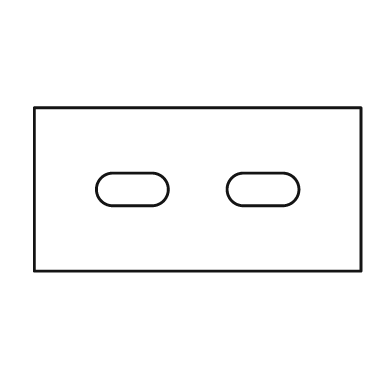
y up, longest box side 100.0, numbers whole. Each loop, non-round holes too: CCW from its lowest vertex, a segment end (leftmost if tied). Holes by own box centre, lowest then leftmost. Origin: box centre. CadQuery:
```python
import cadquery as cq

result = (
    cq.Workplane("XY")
    .moveTo(-50.0, -25.0)
    .lineTo(50.0, -25.0)
    .lineTo(50.0, 25.0)
    .lineTo(-50.0, 25.0)
    .close()
    .moveTo(-26.0, -5.0)
    .lineTo(-14.0, -5.0)
    .threePointArc((-9.0, 0.0), (-14.0, 5.0))
    .lineTo(-26.0, 5.0)
    .threePointArc((-31.0, 0.0), (-26.0, -5.0))
    .close()
    .moveTo(14.0, -5.0)
    .lineTo(26.0, -5.0)
    .threePointArc((31.0, 0.0), (26.0, 5.0))
    .lineTo(14.0, 5.0)
    .threePointArc((9.0, 0.0), (14.0, -5.0))
    .close()
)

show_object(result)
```